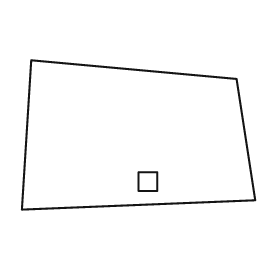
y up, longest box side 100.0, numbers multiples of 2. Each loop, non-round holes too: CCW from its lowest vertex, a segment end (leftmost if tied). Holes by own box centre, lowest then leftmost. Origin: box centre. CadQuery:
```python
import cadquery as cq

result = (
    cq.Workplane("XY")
    .moveTo(-50.0, -32.0)
    .lineTo(50.0, -28.0)
    .lineTo(42.0, 24.0)
    .lineTo(-46.0, 32.0)
    .close()
    .moveTo(0.0, -24.0)
    .lineTo(8.0, -24.0)
    .lineTo(8.0, -16.0)
    .lineTo(0.0, -16.0)
    .close()
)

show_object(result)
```